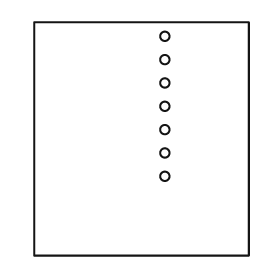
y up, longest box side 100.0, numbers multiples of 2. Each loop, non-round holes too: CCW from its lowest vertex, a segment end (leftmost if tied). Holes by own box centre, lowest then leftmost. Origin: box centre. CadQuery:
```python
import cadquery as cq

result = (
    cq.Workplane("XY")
    .moveTo(-46.0, -50.0)
    .lineTo(46.0, -50.0)
    .lineTo(46.0, 50.0)
    .lineTo(-46.0, 50.0)
    .close()
    .moveTo(10.0, -16.0)
    .circle(2.0)
    .moveTo(10.0, -6.0)
    .circle(2.0)
    .moveTo(10.0, 4.0)
    .circle(2.0)
    .moveTo(10.0, 14.0)
    .circle(2.0)
    .moveTo(10.0, 24.0)
    .circle(2.0)
    .moveTo(10.0, 34.0)
    .circle(2.0)
    .moveTo(10.0, 44.0)
    .circle(2.0)
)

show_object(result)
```